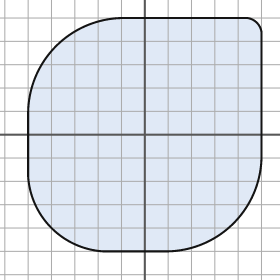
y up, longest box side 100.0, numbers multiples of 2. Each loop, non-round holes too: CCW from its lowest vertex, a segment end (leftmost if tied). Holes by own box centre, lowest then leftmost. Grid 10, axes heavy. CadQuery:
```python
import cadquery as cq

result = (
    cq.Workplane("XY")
    .moveTo(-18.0, -50.0)
    .lineTo(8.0, -50.0)
    .threePointArc((38.0, -38.0), (50.0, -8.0))
    .lineTo(50.0, 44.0)
    .threePointArc((48.0, 48.0), (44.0, 50.0))
    .lineTo(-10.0, 50.0)
    .threePointArc((-38.0, 38.0), (-50.0, 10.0))
    .lineTo(-50.0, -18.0)
    .threePointArc((-40.0, -40.0), (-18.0, -50.0))
    .close()
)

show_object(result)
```